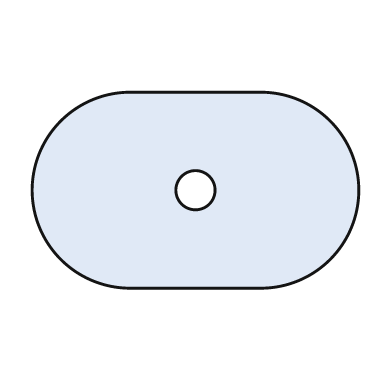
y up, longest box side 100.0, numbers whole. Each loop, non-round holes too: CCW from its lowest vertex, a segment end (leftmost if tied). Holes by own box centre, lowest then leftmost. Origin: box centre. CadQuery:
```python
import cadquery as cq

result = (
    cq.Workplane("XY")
    .moveTo(-20.0, -30.0)
    .lineTo(20.0, -30.0)
    .threePointArc((50.0, 0.0), (20.0, 30.0))
    .lineTo(-20.0, 30.0)
    .threePointArc((-50.0, 0.0), (-20.0, -30.0))
    .close()
    .moveTo(0.0, 0.0)
    .circle(6.0)
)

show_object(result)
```